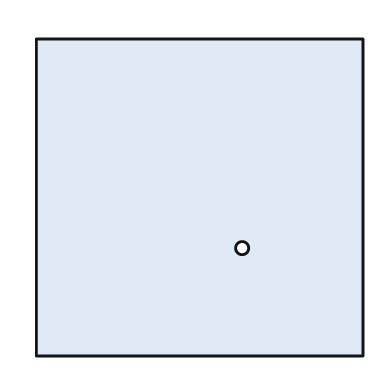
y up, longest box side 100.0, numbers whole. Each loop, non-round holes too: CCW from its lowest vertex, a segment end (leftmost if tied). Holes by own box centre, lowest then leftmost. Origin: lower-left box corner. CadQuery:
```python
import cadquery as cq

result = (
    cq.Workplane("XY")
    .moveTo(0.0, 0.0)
    .lineTo(100.0, 0.0)
    .lineTo(100.0, 97.0)
    .lineTo(0.0, 97.0)
    .close()
    .moveTo(63.0, 33.0)
    .circle(2.0)
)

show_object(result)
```